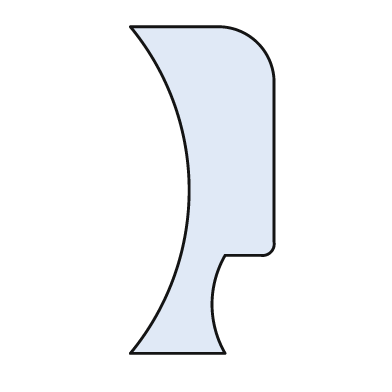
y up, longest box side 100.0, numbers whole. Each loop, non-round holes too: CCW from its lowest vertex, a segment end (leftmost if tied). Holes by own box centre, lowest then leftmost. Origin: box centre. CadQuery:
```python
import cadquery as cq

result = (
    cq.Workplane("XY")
    .moveTo(-22.0, -50.0)
    .lineTo(7.0, -50.0)
    .threePointArc((3.0, -35.0), (7.0, -20.0))
    .lineTo(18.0, -20.0)
    .threePointArc((21.0, -19.0), (22.0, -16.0))
    .lineTo(22.0, 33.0)
    .threePointArc((17.0, 45.0), (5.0, 50.0))
    .lineTo(-22.0, 50.0)
    .threePointArc((-4.0, 0.0), (-22.0, -50.0))
    .close()
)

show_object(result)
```